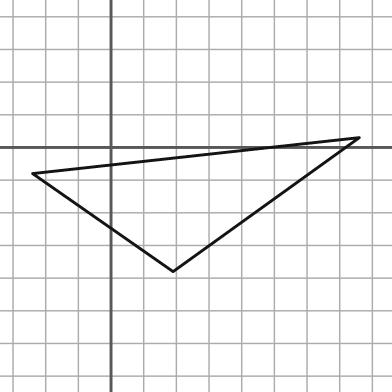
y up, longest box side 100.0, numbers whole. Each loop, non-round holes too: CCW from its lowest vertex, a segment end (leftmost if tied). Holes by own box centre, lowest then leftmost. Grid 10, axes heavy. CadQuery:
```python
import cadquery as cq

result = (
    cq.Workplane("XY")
    .moveTo(19.0, -38.0)
    .lineTo(76.0, 3.0)
    .lineTo(-24.0, -8.0)
    .close()
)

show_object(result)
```